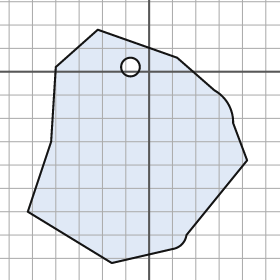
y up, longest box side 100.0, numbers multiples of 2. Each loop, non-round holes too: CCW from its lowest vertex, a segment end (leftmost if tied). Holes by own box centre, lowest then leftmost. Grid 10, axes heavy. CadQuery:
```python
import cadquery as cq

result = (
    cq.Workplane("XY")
    .moveTo(-16.0, -82.0)
    .lineTo(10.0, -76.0)
    .threePointArc((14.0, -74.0), (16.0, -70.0))
    .lineTo(42.0, -38.0)
    .lineTo(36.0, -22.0)
    .threePointArc((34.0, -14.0), (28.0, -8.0))
    .lineTo(12.0, 6.0)
    .lineTo(-22.0, 18.0)
    .lineTo(-40.0, 2.0)
    .lineTo(-42.0, -30.0)
    .lineTo(-52.0, -60.0)
    .close()
    .moveTo(-8.0, 2.0)
    .circle(4.0)
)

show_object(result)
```